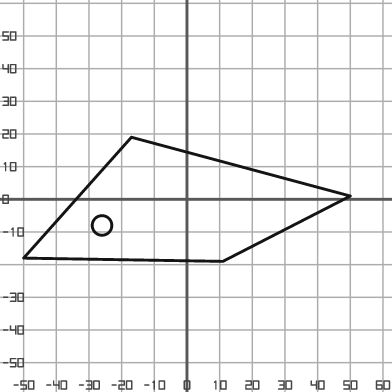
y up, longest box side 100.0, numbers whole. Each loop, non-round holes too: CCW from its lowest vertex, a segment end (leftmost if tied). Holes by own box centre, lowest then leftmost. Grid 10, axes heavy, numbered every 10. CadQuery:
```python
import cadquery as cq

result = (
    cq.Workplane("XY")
    .moveTo(11.0, -19.0)
    .lineTo(50.0, 1.0)
    .lineTo(-17.0, 19.0)
    .lineTo(-50.0, -18.0)
    .close()
    .moveTo(-26.0, -8.0)
    .circle(3.0)
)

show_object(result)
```